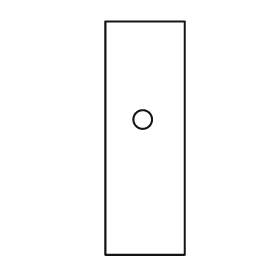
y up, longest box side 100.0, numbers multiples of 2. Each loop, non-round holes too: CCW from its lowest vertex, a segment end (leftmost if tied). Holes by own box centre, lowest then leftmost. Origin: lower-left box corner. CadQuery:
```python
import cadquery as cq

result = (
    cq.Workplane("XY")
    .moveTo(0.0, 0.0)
    .lineTo(34.0, 0.0)
    .lineTo(34.0, 100.0)
    .lineTo(0.0, 100.0)
    .close()
    .moveTo(16.0, 58.0)
    .circle(4.0)
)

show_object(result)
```